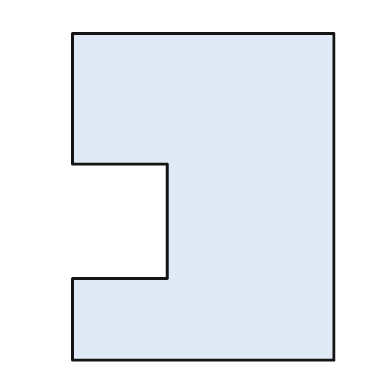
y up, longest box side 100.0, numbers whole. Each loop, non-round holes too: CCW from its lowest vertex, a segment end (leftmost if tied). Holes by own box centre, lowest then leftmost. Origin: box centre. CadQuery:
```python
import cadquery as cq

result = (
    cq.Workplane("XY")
    .moveTo(-40.0, -50.0)
    .lineTo(40.0, -50.0)
    .lineTo(40.0, 50.0)
    .lineTo(-40.0, 50.0)
    .lineTo(-40.0, 10.0)
    .lineTo(-11.0, 10.0)
    .lineTo(-11.0, -25.0)
    .lineTo(-40.0, -25.0)
    .close()
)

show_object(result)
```